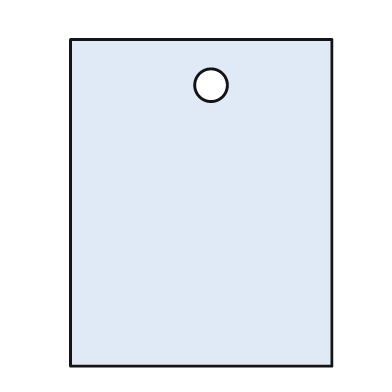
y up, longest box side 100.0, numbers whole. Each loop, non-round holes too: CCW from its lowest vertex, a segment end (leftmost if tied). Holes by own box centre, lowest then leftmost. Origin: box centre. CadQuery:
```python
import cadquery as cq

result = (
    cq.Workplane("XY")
    .moveTo(-40.0, -50.0)
    .lineTo(40.0, -50.0)
    .lineTo(40.0, 50.0)
    .lineTo(-40.0, 50.0)
    .close()
    .moveTo(3.0, 36.0)
    .circle(5.0)
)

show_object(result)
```